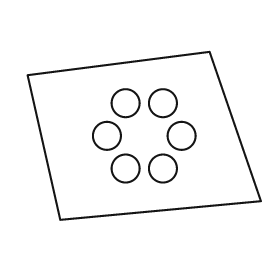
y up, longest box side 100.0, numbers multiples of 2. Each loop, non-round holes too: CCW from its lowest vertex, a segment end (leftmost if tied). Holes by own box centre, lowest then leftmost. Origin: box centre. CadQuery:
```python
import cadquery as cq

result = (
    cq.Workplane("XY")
    .moveTo(-36.0, -36.0)
    .lineTo(50.0, -28.0)
    .lineTo(28.0, 36.0)
    .lineTo(-50.0, 26.0)
    .close()
    .moveTo(-8.0, -14.0)
    .circle(6.0)
    .moveTo(8.0, -14.0)
    .circle(6.0)
    .moveTo(-16.0, 0.0)
    .circle(6.0)
    .moveTo(16.0, 0.0)
    .circle(6.0)
    .moveTo(-8.0, 14.0)
    .circle(6.0)
    .moveTo(8.0, 14.0)
    .circle(6.0)
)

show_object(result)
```